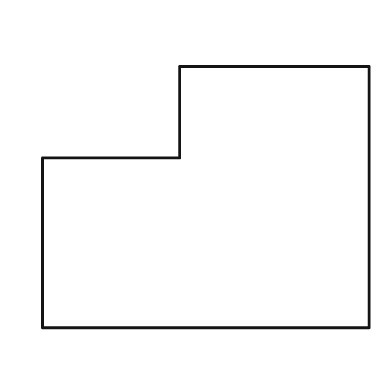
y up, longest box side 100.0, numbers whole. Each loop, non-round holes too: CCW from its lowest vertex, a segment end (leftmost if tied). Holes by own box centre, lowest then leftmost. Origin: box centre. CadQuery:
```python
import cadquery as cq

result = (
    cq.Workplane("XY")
    .moveTo(-50.0, -40.0)
    .lineTo(50.0, -40.0)
    .lineTo(50.0, 40.0)
    .lineTo(-8.0, 40.0)
    .lineTo(-8.0, 12.0)
    .lineTo(-50.0, 12.0)
    .close()
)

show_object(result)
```